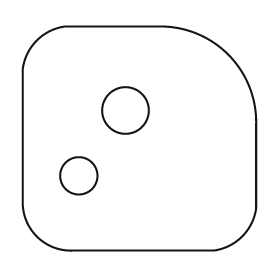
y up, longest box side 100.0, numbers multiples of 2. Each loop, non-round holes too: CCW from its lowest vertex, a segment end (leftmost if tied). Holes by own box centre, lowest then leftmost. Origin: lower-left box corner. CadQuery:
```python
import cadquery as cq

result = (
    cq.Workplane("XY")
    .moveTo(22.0, 0.0)
    .lineTo(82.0, 0.0)
    .threePointArc((94.0, 6.0), (100.0, 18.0))
    .lineTo(100.0, 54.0)
    .threePointArc((88.0, 84.0), (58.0, 96.0))
    .lineTo(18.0, 96.0)
    .threePointArc((6.0, 90.0), (0.0, 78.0))
    .lineTo(0.0, 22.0)
    .threePointArc((6.0, 6.0), (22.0, 0.0))
    .close()
    .moveTo(24.0, 32.0)
    .circle(8.0)
    .moveTo(44.0, 60.0)
    .circle(10.0)
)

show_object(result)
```